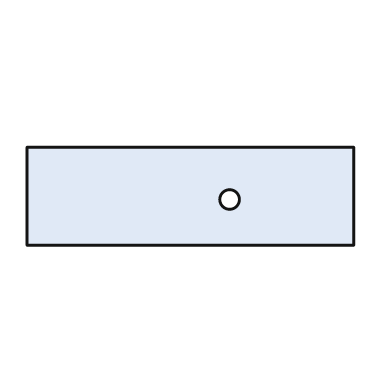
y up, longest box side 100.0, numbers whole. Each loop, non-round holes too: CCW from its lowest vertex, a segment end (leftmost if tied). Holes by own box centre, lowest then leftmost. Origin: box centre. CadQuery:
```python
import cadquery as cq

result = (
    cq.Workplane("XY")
    .moveTo(-50.0, -15.0)
    .lineTo(50.0, -15.0)
    .lineTo(50.0, 15.0)
    .lineTo(-50.0, 15.0)
    .close()
    .moveTo(12.0, -1.0)
    .circle(3.0)
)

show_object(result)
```